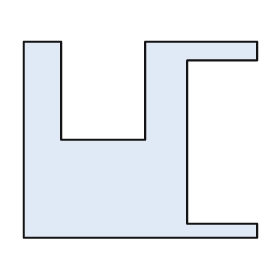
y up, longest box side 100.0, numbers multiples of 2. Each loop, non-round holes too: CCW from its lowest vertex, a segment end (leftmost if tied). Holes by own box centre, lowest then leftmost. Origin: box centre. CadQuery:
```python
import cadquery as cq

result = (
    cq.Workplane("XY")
    .moveTo(-50.0, -42.0)
    .lineTo(50.0, -42.0)
    .lineTo(50.0, -36.0)
    .lineTo(20.0, -36.0)
    .lineTo(20.0, 34.0)
    .lineTo(50.0, 34.0)
    .lineTo(50.0, 42.0)
    .lineTo(2.0, 42.0)
    .lineTo(2.0, 0.0)
    .lineTo(-34.0, 0.0)
    .lineTo(-34.0, 42.0)
    .lineTo(-50.0, 42.0)
    .close()
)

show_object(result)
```